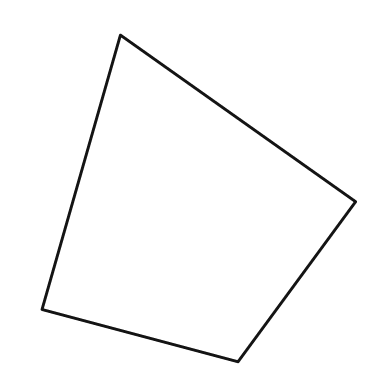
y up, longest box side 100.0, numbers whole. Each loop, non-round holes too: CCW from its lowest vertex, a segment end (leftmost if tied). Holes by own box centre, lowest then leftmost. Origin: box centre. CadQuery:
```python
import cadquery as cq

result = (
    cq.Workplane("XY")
    .moveTo(12.0, -50.0)
    .lineTo(48.0, -1.0)
    .lineTo(-24.0, 50.0)
    .lineTo(-48.0, -34.0)
    .close()
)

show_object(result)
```